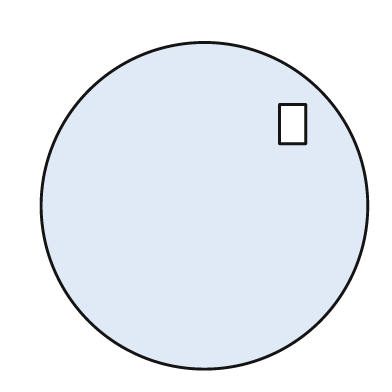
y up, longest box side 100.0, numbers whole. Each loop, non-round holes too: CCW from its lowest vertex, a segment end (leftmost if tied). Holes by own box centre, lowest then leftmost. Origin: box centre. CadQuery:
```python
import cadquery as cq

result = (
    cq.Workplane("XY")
    .moveTo(0.0, 0.0)
    .circle(50.0)
    .moveTo(23.0, 19.0)
    .lineTo(31.0, 19.0)
    .lineTo(31.0, 31.0)
    .lineTo(23.0, 31.0)
    .close()
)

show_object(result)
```